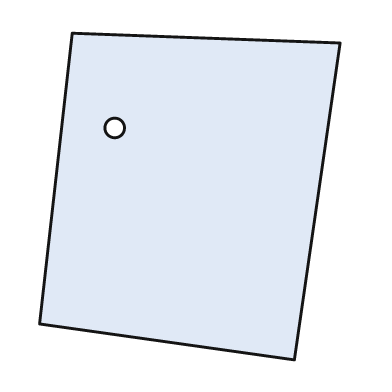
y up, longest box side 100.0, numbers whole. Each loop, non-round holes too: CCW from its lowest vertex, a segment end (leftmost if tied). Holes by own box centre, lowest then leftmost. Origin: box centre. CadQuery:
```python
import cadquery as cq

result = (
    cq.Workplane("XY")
    .moveTo(32.0, -50.0)
    .lineTo(46.0, 47.0)
    .lineTo(-36.0, 50.0)
    .lineTo(-46.0, -39.0)
    .close()
    .moveTo(-23.0, 21.0)
    .circle(3.0)
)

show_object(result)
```